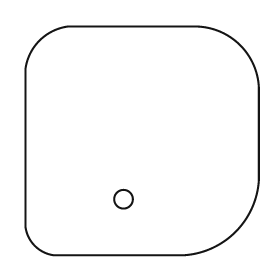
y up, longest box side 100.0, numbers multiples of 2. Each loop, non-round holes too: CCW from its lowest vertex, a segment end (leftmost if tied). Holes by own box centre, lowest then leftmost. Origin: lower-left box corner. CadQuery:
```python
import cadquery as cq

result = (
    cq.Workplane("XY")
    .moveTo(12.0, 0.0)
    .lineTo(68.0, 0.0)
    .threePointArc((90.0, 10.0), (100.0, 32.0))
    .lineTo(100.0, 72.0)
    .threePointArc((92.0, 90.0), (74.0, 98.0))
    .lineTo(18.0, 98.0)
    .threePointArc((6.0, 92.0), (0.0, 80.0))
    .lineTo(0.0, 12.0)
    .threePointArc((4.0, 4.0), (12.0, 0.0))
    .close()
    .moveTo(42.0, 24.0)
    .circle(4.0)
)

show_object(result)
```